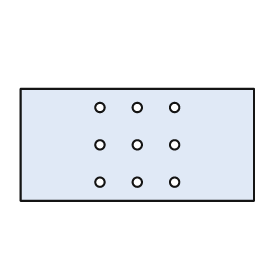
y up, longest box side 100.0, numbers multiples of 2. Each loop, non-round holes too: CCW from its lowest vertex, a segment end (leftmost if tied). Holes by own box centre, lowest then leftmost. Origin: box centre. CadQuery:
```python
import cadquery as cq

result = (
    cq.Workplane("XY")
    .moveTo(-50.0, -24.0)
    .lineTo(50.0, -24.0)
    .lineTo(50.0, 24.0)
    .lineTo(-50.0, 24.0)
    .close()
    .moveTo(-16.0, -16.0)
    .circle(2.0)
    .moveTo(0.0, -16.0)
    .circle(2.0)
    .moveTo(16.0, -16.0)
    .circle(2.0)
    .moveTo(-16.0, 0.0)
    .circle(2.0)
    .moveTo(0.0, 0.0)
    .circle(2.0)
    .moveTo(16.0, 0.0)
    .circle(2.0)
    .moveTo(-16.0, 16.0)
    .circle(2.0)
    .moveTo(0.0, 16.0)
    .circle(2.0)
    .moveTo(16.0, 16.0)
    .circle(2.0)
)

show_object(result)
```